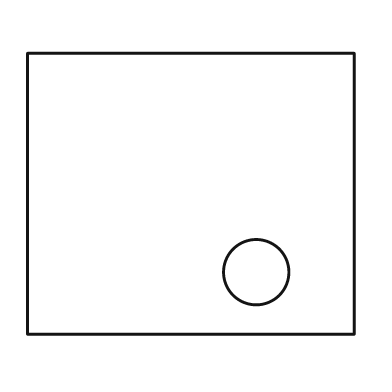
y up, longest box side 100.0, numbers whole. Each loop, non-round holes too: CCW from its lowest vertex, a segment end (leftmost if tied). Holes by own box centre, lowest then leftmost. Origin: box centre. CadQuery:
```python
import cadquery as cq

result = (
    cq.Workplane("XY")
    .moveTo(-50.0, -43.0)
    .lineTo(50.0, -43.0)
    .lineTo(50.0, 43.0)
    .lineTo(-50.0, 43.0)
    .close()
    .moveTo(20.0, -24.0)
    .circle(10.0)
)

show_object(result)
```